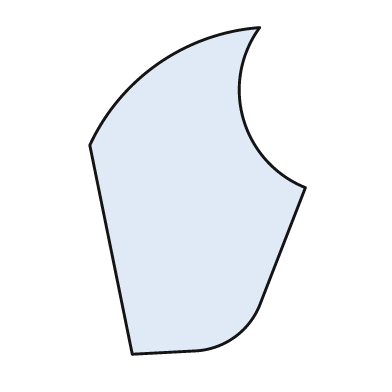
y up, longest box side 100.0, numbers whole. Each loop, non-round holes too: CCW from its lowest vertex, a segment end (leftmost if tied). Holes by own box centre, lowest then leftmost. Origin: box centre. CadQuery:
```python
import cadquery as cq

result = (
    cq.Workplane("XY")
    .moveTo(-20.0, -50.0)
    .lineTo(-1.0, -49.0)
    .threePointArc((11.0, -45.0), (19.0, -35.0))
    .lineTo(33.0, 1.0)
    .threePointArc((14.0, 22.0), (19.0, 50.0))
    .threePointArc((-12.0, 39.0), (-33.0, 14.0))
    .close()
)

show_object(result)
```